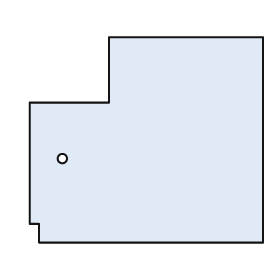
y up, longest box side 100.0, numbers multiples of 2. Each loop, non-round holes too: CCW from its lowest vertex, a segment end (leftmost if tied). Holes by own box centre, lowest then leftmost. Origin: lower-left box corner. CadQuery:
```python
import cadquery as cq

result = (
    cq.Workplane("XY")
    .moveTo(4.0, 0.0)
    .lineTo(100.0, 0.0)
    .lineTo(100.0, 88.0)
    .lineTo(34.0, 88.0)
    .lineTo(34.0, 60.0)
    .lineTo(0.0, 60.0)
    .lineTo(0.0, 8.0)
    .lineTo(4.0, 8.0)
    .close()
    .moveTo(14.0, 36.0)
    .circle(2.0)
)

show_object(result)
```